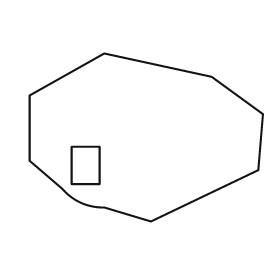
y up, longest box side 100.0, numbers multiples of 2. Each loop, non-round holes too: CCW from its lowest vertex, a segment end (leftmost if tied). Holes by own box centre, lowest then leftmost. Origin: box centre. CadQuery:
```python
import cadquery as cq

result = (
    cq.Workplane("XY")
    .moveTo(2.0, -36.0)
    .lineTo(48.0, -14.0)
    .lineTo(50.0, 10.0)
    .lineTo(28.0, 26.0)
    .lineTo(-18.0, 36.0)
    .lineTo(-50.0, 18.0)
    .lineTo(-50.0, -10.0)
    .lineTo(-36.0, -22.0)
    .threePointArc((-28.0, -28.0), (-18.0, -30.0))
    .close()
    .moveTo(-32.0, -20.0)
    .lineTo(-20.0, -20.0)
    .lineTo(-20.0, -4.0)
    .lineTo(-32.0, -4.0)
    .close()
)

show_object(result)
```